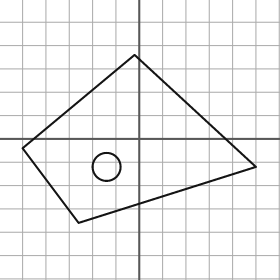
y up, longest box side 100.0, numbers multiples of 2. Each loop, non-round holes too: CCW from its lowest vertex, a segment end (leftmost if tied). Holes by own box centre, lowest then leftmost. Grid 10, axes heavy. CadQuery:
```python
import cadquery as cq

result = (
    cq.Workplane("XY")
    .moveTo(-26.0, -36.0)
    .lineTo(50.0, -12.0)
    .lineTo(-2.0, 36.0)
    .lineTo(-50.0, -4.0)
    .close()
    .moveTo(-14.0, -12.0)
    .circle(6.0)
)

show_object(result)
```